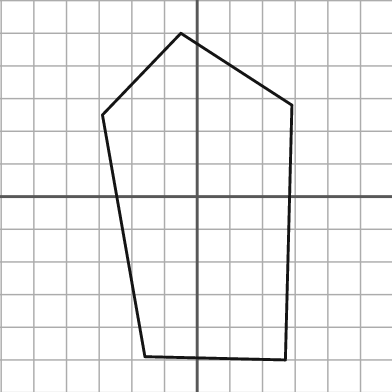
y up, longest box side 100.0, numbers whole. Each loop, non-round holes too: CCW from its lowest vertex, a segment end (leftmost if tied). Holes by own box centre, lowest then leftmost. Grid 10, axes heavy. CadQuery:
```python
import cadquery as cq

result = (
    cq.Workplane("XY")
    .moveTo(27.0, -50.0)
    .lineTo(29.0, 28.0)
    .lineTo(-5.0, 50.0)
    .lineTo(-29.0, 25.0)
    .lineTo(-16.0, -49.0)
    .close()
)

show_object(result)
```